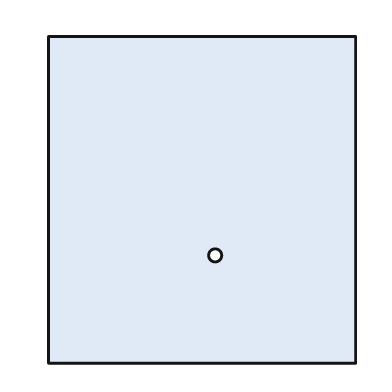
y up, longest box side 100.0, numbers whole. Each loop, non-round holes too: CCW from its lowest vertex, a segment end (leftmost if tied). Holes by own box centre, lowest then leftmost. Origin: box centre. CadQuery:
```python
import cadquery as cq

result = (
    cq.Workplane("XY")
    .moveTo(-47.0, -50.0)
    .lineTo(47.0, -50.0)
    .lineTo(47.0, 50.0)
    .lineTo(-47.0, 50.0)
    .close()
    .moveTo(4.0, -17.0)
    .circle(2.0)
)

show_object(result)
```